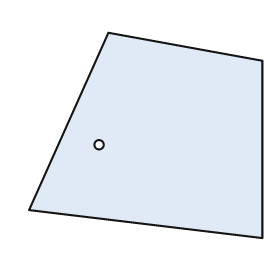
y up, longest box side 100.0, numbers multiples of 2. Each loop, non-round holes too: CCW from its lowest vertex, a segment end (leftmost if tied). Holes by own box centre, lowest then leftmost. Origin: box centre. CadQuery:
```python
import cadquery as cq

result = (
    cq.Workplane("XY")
    .moveTo(50.0, -44.0)
    .lineTo(50.0, 32.0)
    .lineTo(-16.0, 44.0)
    .lineTo(-50.0, -32.0)
    .close()
    .moveTo(-20.0, -4.0)
    .circle(2.0)
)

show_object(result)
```